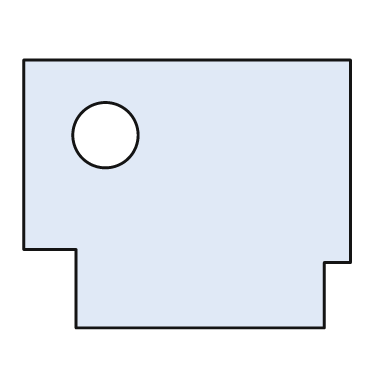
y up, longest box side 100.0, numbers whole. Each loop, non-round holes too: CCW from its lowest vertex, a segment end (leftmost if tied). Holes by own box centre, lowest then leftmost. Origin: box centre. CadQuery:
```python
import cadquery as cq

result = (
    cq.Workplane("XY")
    .moveTo(-34.0, -41.0)
    .lineTo(42.0, -41.0)
    .lineTo(42.0, -21.0)
    .lineTo(50.0, -21.0)
    .lineTo(50.0, 41.0)
    .lineTo(-50.0, 41.0)
    .lineTo(-50.0, -17.0)
    .lineTo(-34.0, -17.0)
    .close()
    .moveTo(-25.0, 18.0)
    .circle(10.0)
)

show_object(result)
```